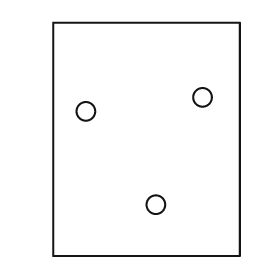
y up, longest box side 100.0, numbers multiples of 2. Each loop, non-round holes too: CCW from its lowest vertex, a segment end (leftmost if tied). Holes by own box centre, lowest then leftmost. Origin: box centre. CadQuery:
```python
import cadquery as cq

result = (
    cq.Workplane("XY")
    .moveTo(-40.0, -50.0)
    .lineTo(40.0, -50.0)
    .lineTo(40.0, 50.0)
    .lineTo(-40.0, 50.0)
    .close()
    .moveTo(4.0, -28.0)
    .circle(4.0)
    .moveTo(-26.0, 12.0)
    .circle(4.0)
    .moveTo(24.0, 18.0)
    .circle(4.0)
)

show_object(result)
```